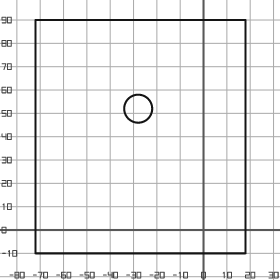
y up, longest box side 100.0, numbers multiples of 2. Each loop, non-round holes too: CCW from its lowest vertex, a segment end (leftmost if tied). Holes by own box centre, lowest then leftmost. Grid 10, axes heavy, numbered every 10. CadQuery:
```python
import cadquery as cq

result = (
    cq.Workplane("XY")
    .moveTo(-72.0, -10.0)
    .lineTo(18.0, -10.0)
    .lineTo(18.0, 90.0)
    .lineTo(-72.0, 90.0)
    .close()
    .moveTo(-28.0, 52.0)
    .circle(6.0)
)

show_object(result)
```